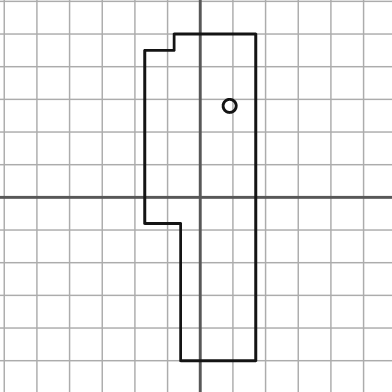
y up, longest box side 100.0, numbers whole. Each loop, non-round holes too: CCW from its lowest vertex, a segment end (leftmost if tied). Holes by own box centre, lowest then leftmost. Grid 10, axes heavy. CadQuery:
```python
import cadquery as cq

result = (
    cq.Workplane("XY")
    .moveTo(-6.0, -50.0)
    .lineTo(17.0, -50.0)
    .lineTo(17.0, 50.0)
    .lineTo(-8.0, 50.0)
    .lineTo(-8.0, 45.0)
    .lineTo(-17.0, 45.0)
    .lineTo(-17.0, -8.0)
    .lineTo(-6.0, -8.0)
    .close()
    .moveTo(9.0, 28.0)
    .circle(2.0)
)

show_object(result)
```